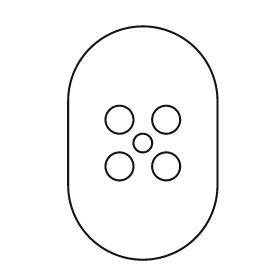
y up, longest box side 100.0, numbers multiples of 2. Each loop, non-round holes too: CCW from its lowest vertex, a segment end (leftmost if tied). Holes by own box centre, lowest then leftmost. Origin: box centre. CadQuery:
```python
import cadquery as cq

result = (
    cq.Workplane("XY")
    .moveTo(-32.0, -18.0)
    .threePointArc((0.0, -50.0), (32.0, -18.0))
    .lineTo(32.0, 18.0)
    .threePointArc((0.0, 50.0), (-32.0, 18.0))
    .close()
    .moveTo(-10.0, -10.0)
    .circle(6.0)
    .moveTo(10.0, -10.0)
    .circle(6.0)
    .moveTo(0.0, 0.0)
    .circle(4.0)
    .moveTo(-10.0, 10.0)
    .circle(6.0)
    .moveTo(10.0, 10.0)
    .circle(6.0)
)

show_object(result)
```